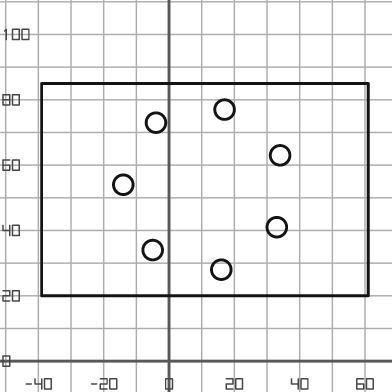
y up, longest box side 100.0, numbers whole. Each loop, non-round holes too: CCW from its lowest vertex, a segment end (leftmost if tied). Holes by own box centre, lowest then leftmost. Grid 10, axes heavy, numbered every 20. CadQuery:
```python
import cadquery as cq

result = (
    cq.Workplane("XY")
    .moveTo(-39.0, 20.0)
    .lineTo(61.0, 20.0)
    .lineTo(61.0, 85.0)
    .lineTo(-39.0, 85.0)
    .close()
    .moveTo(16.0, 28.0)
    .circle(3.0)
    .moveTo(-5.0, 34.0)
    .circle(3.0)
    .moveTo(33.0, 41.0)
    .circle(3.0)
    .moveTo(-14.0, 54.0)
    .circle(3.0)
    .moveTo(34.0, 63.0)
    .circle(3.0)
    .moveTo(-4.0, 73.0)
    .circle(3.0)
    .moveTo(17.0, 77.0)
    .circle(3.0)
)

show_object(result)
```